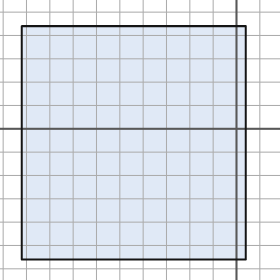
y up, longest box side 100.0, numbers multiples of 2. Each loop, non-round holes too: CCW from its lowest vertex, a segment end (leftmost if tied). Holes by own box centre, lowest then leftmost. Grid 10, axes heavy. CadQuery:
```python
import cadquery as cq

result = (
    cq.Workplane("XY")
    .moveTo(-92.0, -56.0)
    .lineTo(4.0, -56.0)
    .lineTo(4.0, 44.0)
    .lineTo(-92.0, 44.0)
    .close()
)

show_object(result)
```